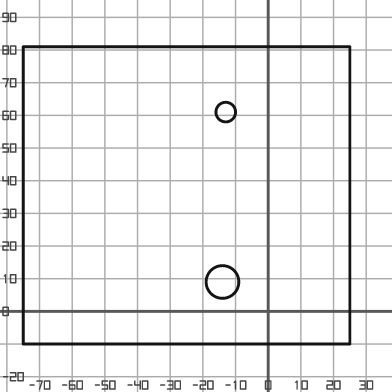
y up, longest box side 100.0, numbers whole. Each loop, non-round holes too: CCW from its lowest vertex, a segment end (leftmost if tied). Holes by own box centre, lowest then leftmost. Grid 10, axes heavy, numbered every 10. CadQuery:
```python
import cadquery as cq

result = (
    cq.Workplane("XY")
    .moveTo(-75.0, -10.0)
    .lineTo(25.0, -10.0)
    .lineTo(25.0, 81.0)
    .lineTo(-75.0, 81.0)
    .close()
    .moveTo(-14.0, 9.0)
    .circle(5.0)
    .moveTo(-13.0, 61.0)
    .circle(3.0)
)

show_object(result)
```